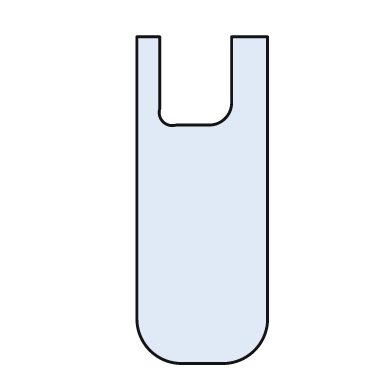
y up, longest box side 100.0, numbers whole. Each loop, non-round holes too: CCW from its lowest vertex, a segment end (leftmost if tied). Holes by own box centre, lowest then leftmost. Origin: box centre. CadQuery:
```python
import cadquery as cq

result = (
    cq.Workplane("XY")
    .moveTo(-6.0, -50.0)
    .lineTo(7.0, -50.0)
    .threePointArc((16.0, -46.0), (20.0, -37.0))
    .lineTo(20.0, 50.0)
    .lineTo(9.0, 50.0)
    .lineTo(9.0, 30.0)
    .threePointArc((7.0, 25.0), (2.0, 23.0))
    .lineTo(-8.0, 23.0)
    .threePointArc((-12.0, 24.0), (-13.0, 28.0))
    .lineTo(-13.0, 50.0)
    .lineTo(-20.0, 50.0)
    .lineTo(-20.0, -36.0)
    .threePointArc((-16.0, -46.0), (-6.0, -50.0))
    .close()
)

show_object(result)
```